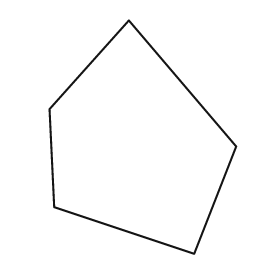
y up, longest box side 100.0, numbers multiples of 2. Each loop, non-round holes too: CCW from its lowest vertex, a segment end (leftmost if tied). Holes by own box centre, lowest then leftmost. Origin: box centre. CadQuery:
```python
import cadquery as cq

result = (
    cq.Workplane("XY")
    .moveTo(22.0, -50.0)
    .lineTo(40.0, -4.0)
    .lineTo(-6.0, 50.0)
    .lineTo(-40.0, 12.0)
    .lineTo(-38.0, -30.0)
    .close()
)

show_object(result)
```